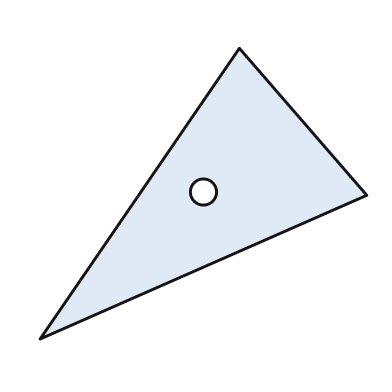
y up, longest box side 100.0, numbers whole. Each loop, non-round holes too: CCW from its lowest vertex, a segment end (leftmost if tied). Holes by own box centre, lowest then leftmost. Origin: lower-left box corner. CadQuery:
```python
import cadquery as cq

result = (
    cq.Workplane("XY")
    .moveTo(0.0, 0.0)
    .lineTo(100.0, 44.0)
    .lineTo(61.0, 89.0)
    .close()
    .moveTo(50.0, 45.0)
    .circle(4.0)
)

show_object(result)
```